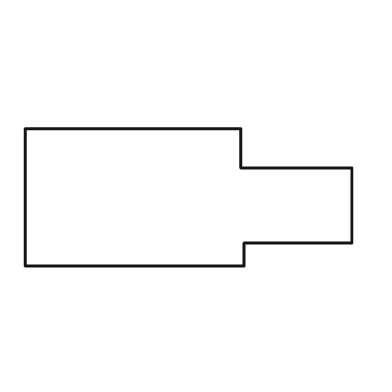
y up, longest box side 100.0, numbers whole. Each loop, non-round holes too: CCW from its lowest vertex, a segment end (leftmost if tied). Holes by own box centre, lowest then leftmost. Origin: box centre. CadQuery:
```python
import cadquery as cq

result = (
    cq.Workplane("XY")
    .moveTo(-50.0, -21.0)
    .lineTo(17.0, -21.0)
    .lineTo(17.0, -14.0)
    .lineTo(50.0, -14.0)
    .lineTo(50.0, 9.0)
    .lineTo(16.0, 9.0)
    .lineTo(16.0, 21.0)
    .lineTo(-50.0, 21.0)
    .close()
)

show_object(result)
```